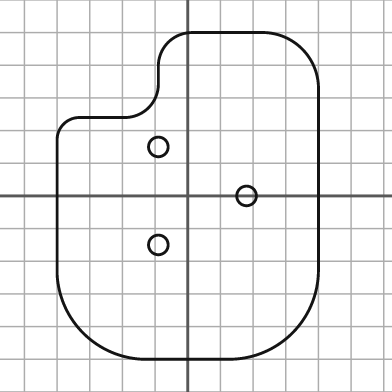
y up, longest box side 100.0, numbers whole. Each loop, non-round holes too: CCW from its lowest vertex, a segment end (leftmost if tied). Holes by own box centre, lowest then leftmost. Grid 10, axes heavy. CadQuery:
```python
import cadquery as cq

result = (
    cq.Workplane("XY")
    .moveTo(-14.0, -50.0)
    .lineTo(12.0, -50.0)
    .threePointArc((32.0, -42.0), (40.0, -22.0))
    .lineTo(40.0, 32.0)
    .threePointArc((35.0, 45.0), (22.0, 50.0))
    .lineTo(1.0, 50.0)
    .threePointArc((-6.0, 47.0), (-9.0, 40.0))
    .lineTo(-9.0, 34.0)
    .threePointArc((-12.0, 27.0), (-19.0, 24.0))
    .lineTo(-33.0, 24.0)
    .threePointArc((-38.0, 22.0), (-40.0, 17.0))
    .lineTo(-40.0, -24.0)
    .threePointArc((-32.0, -42.0), (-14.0, -50.0))
    .close()
    .moveTo(-9.0, -15.0)
    .circle(3.0)
    .moveTo(18.0, 0.0)
    .circle(3.0)
    .moveTo(-9.0, 15.0)
    .circle(3.0)
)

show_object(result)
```